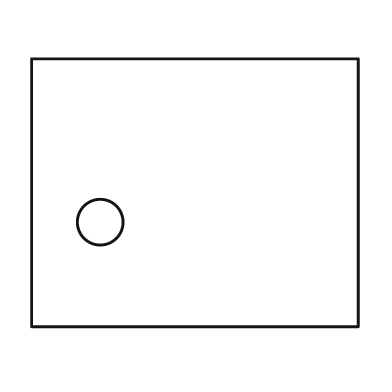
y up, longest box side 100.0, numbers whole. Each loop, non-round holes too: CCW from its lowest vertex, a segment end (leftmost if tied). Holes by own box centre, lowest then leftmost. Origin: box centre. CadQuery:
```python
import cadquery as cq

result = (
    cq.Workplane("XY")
    .moveTo(-50.0, -41.0)
    .lineTo(50.0, -41.0)
    .lineTo(50.0, 41.0)
    .lineTo(-50.0, 41.0)
    .close()
    .moveTo(-29.0, -9.0)
    .circle(7.0)
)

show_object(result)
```